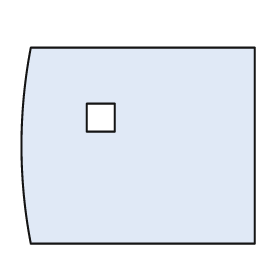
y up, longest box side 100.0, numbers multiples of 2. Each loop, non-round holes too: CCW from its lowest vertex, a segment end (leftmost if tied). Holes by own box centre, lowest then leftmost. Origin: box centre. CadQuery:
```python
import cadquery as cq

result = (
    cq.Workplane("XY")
    .moveTo(-46.0, -42.0)
    .lineTo(50.0, -42.0)
    .lineTo(50.0, 42.0)
    .lineTo(-46.0, 42.0)
    .threePointArc((-50.0, 0.0), (-46.0, -42.0))
    .close()
    .moveTo(-22.0, 6.0)
    .lineTo(-10.0, 6.0)
    .lineTo(-10.0, 18.0)
    .lineTo(-22.0, 18.0)
    .close()
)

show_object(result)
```